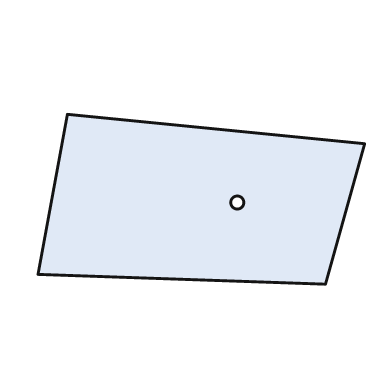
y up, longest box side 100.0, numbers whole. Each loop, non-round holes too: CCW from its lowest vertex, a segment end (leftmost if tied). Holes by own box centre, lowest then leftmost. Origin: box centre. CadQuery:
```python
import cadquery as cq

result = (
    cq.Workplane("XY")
    .moveTo(38.0, -26.0)
    .lineTo(50.0, 17.0)
    .lineTo(-41.0, 26.0)
    .lineTo(-50.0, -23.0)
    .close()
    .moveTo(11.0, -1.0)
    .circle(2.0)
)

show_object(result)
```